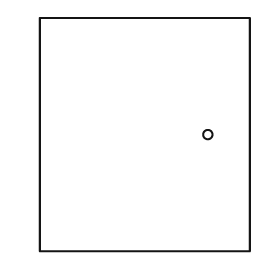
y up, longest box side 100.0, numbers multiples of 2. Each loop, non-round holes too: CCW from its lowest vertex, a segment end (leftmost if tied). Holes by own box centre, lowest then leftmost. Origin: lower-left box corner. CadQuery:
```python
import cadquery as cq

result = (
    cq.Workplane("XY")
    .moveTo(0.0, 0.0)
    .lineTo(90.0, 0.0)
    .lineTo(90.0, 100.0)
    .lineTo(0.0, 100.0)
    .close()
    .moveTo(72.0, 50.0)
    .circle(2.0)
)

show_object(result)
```